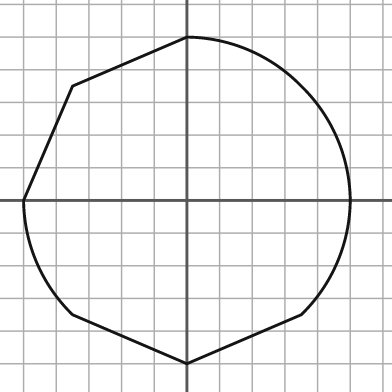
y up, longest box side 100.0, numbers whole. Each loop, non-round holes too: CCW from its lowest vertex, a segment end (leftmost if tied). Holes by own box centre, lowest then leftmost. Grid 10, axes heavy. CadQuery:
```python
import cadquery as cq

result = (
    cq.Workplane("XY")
    .moveTo(0.0, -50.0)
    .lineTo(35.0, -35.0)
    .threePointArc((46.0, -19.0), (50.0, 0.0))
    .threePointArc((46.0, 19.0), (35.0, 35.0))
    .threePointArc((19.0, 46.0), (0.0, 50.0))
    .lineTo(-35.0, 35.0)
    .lineTo(-50.0, 0.0)
    .threePointArc((-46.0, -19.0), (-35.0, -35.0))
    .close()
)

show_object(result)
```